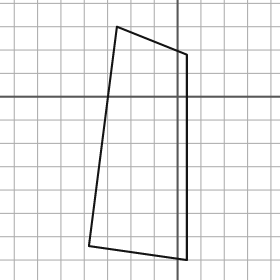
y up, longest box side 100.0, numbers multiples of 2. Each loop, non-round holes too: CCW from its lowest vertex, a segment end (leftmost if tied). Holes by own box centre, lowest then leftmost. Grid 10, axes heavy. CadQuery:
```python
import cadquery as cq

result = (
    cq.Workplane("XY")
    .moveTo(4.0, -70.0)
    .lineTo(4.0, 18.0)
    .lineTo(-26.0, 30.0)
    .lineTo(-38.0, -64.0)
    .close()
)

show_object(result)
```